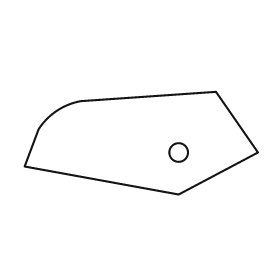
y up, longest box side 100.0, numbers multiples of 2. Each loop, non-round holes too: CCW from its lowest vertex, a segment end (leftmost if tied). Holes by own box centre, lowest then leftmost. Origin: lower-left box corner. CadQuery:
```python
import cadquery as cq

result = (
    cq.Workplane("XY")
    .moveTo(66.0, 0.0)
    .lineTo(100.0, 18.0)
    .lineTo(82.0, 44.0)
    .lineTo(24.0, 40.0)
    .threePointArc((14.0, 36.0), (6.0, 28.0))
    .lineTo(0.0, 12.0)
    .close()
    .moveTo(66.0, 18.0)
    .circle(4.0)
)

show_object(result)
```